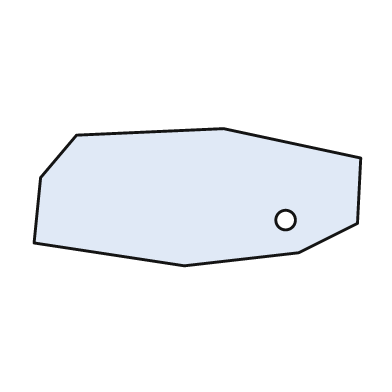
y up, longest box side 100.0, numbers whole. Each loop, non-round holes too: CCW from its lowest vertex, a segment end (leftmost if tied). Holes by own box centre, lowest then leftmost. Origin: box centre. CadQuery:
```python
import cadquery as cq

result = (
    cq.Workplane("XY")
    .moveTo(-4.0, -21.0)
    .lineTo(31.0, -17.0)
    .lineTo(49.0, -8.0)
    .lineTo(50.0, 12.0)
    .lineTo(8.0, 21.0)
    .lineTo(-37.0, 19.0)
    .lineTo(-48.0, 6.0)
    .lineTo(-50.0, -14.0)
    .close()
    .moveTo(27.0, -7.0)
    .circle(3.0)
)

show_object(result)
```